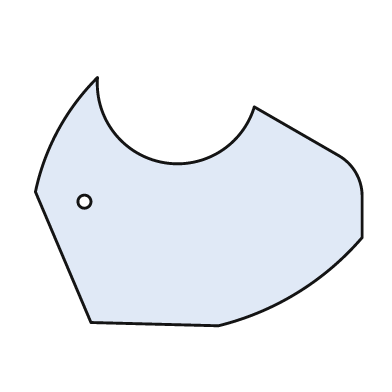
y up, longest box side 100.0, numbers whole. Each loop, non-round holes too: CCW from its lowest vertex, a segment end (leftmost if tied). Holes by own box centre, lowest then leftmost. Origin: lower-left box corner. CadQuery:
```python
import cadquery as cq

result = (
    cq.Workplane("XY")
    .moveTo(56.0, 0.0)
    .threePointArc((80.0, 10.0), (100.0, 27.0))
    .lineTo(100.0, 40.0)
    .threePointArc((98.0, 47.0), (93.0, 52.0))
    .lineTo(67.0, 67.0)
    .threePointArc((39.0, 50.0), (19.0, 76.0))
    .threePointArc((7.0, 60.0), (0.0, 41.0))
    .lineTo(17.0, 1.0)
    .close()
    .moveTo(15.0, 38.0)
    .circle(2.0)
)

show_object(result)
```